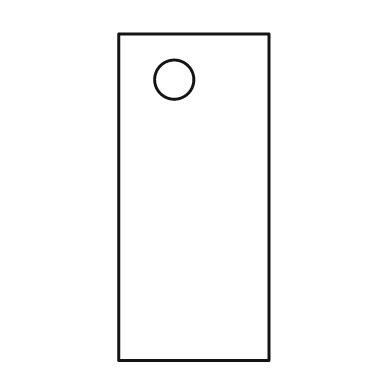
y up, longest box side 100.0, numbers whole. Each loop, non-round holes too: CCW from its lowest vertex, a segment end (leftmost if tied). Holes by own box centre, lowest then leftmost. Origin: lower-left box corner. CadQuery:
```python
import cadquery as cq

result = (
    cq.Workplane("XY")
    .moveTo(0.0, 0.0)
    .lineTo(46.0, 0.0)
    .lineTo(46.0, 100.0)
    .lineTo(0.0, 100.0)
    .close()
    .moveTo(17.0, 86.0)
    .circle(6.0)
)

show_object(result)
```